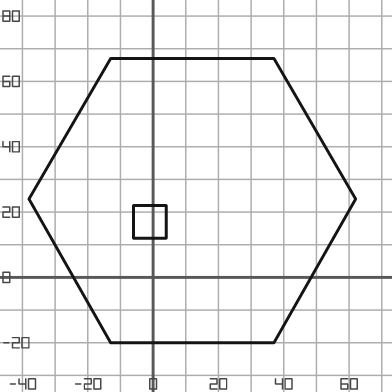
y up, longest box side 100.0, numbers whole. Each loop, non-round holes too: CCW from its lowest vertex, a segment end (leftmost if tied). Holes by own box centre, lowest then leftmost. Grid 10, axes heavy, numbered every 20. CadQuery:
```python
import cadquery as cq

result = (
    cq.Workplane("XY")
    .moveTo(-13.0, -20.0)
    .lineTo(37.0, -20.0)
    .lineTo(62.0, 24.0)
    .lineTo(37.0, 67.0)
    .lineTo(-13.0, 67.0)
    .lineTo(-38.0, 24.0)
    .close()
    .moveTo(-6.0, 12.0)
    .lineTo(4.0, 12.0)
    .lineTo(4.0, 22.0)
    .lineTo(-6.0, 22.0)
    .close()
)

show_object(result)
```